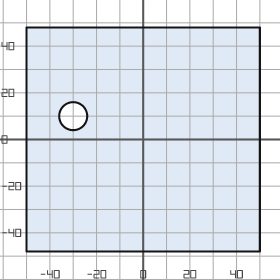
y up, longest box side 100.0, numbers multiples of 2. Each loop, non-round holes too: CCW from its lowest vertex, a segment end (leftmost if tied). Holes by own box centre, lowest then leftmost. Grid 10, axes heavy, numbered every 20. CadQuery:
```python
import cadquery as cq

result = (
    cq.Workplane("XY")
    .moveTo(-50.0, -48.0)
    .lineTo(50.0, -48.0)
    .lineTo(50.0, 48.0)
    .lineTo(-50.0, 48.0)
    .close()
    .moveTo(-30.0, 10.0)
    .circle(6.0)
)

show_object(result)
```